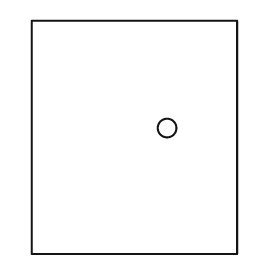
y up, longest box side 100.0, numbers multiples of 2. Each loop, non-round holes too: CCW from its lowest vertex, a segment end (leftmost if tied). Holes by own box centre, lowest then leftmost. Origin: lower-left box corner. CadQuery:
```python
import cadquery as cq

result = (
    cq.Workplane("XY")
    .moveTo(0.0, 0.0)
    .lineTo(88.0, 0.0)
    .lineTo(88.0, 100.0)
    .lineTo(0.0, 100.0)
    .close()
    .moveTo(58.0, 54.0)
    .circle(4.0)
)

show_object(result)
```